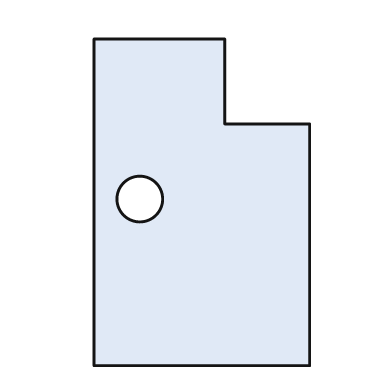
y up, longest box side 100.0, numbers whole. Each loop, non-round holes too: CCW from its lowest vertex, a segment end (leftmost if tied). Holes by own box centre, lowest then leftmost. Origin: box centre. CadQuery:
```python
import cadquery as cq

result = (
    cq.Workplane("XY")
    .moveTo(-33.0, -50.0)
    .lineTo(33.0, -50.0)
    .lineTo(33.0, 24.0)
    .lineTo(7.0, 24.0)
    .lineTo(7.0, 50.0)
    .lineTo(-33.0, 50.0)
    .close()
    .moveTo(-19.0, 1.0)
    .circle(7.0)
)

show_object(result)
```